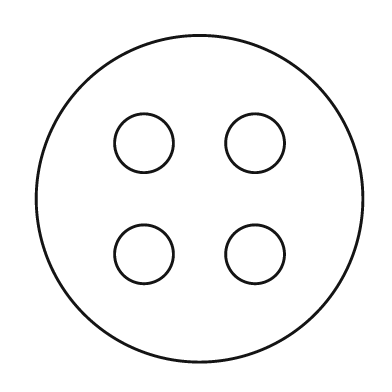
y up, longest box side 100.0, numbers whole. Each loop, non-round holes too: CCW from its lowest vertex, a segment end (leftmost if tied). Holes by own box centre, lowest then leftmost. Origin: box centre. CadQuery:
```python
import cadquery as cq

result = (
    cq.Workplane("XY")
    .moveTo(0.0, 0.0)
    .circle(50.0)
    .moveTo(-17.0, -17.0)
    .circle(9.0)
    .moveTo(17.0, -17.0)
    .circle(9.0)
    .moveTo(-17.0, 17.0)
    .circle(9.0)
    .moveTo(17.0, 17.0)
    .circle(9.0)
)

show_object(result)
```